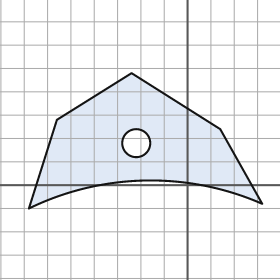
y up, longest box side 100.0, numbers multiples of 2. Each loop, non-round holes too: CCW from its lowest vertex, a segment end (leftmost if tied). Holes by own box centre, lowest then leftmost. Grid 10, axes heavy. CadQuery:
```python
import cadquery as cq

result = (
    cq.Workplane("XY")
    .moveTo(-68.0, -10.0)
    .threePointArc((-18.0, 2.0), (32.0, -8.0))
    .lineTo(14.0, 24.0)
    .lineTo(-24.0, 48.0)
    .lineTo(-56.0, 28.0)
    .close()
    .moveTo(-22.0, 18.0)
    .circle(6.0)
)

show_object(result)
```